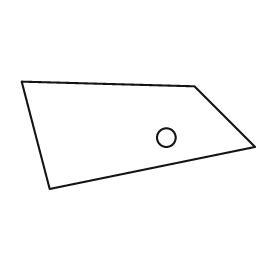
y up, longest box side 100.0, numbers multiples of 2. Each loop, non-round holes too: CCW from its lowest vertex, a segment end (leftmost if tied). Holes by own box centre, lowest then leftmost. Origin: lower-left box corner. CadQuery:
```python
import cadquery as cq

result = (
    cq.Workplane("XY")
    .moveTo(12.0, 0.0)
    .lineTo(100.0, 18.0)
    .lineTo(74.0, 44.0)
    .lineTo(0.0, 46.0)
    .close()
    .moveTo(62.0, 22.0)
    .circle(4.0)
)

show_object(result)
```